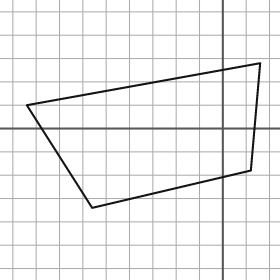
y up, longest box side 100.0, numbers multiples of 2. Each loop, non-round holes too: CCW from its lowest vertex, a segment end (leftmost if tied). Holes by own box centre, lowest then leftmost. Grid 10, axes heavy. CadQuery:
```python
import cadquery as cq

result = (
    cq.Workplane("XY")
    .moveTo(-56.0, -34.0)
    .lineTo(12.0, -18.0)
    .lineTo(16.0, 28.0)
    .lineTo(-84.0, 10.0)
    .close()
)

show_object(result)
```